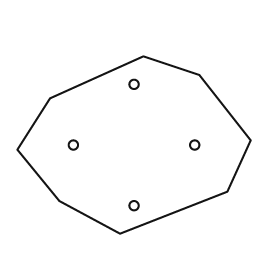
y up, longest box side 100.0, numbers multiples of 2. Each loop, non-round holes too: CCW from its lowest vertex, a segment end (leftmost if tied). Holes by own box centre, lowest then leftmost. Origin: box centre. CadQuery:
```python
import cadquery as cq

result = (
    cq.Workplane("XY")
    .moveTo(-6.0, -38.0)
    .lineTo(40.0, -20.0)
    .lineTo(50.0, 2.0)
    .lineTo(28.0, 30.0)
    .lineTo(4.0, 38.0)
    .lineTo(-36.0, 20.0)
    .lineTo(-50.0, -2.0)
    .lineTo(-32.0, -24.0)
    .close()
    .moveTo(0.0, -26.0)
    .circle(2.0)
    .moveTo(-26.0, 0.0)
    .circle(2.0)
    .moveTo(26.0, 0.0)
    .circle(2.0)
    .moveTo(0.0, 26.0)
    .circle(2.0)
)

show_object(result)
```